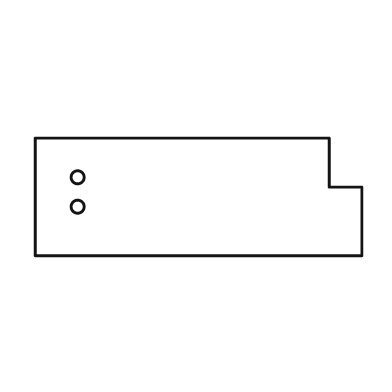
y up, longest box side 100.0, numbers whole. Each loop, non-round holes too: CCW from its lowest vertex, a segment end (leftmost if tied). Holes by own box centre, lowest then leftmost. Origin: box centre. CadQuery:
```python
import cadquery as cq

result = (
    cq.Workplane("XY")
    .moveTo(-50.0, -18.0)
    .lineTo(50.0, -18.0)
    .lineTo(50.0, 3.0)
    .lineTo(40.0, 3.0)
    .lineTo(40.0, 18.0)
    .lineTo(-50.0, 18.0)
    .close()
    .moveTo(-37.0, -3.0)
    .circle(2.0)
    .moveTo(-37.0, 6.0)
    .circle(2.0)
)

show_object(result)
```